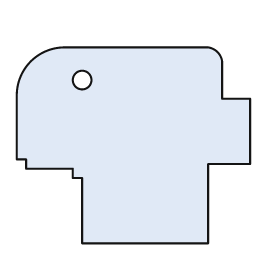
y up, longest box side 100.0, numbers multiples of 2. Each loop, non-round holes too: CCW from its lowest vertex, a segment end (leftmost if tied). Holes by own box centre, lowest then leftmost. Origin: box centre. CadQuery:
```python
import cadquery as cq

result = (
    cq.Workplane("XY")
    .moveTo(-22.0, -42.0)
    .lineTo(32.0, -42.0)
    .lineTo(32.0, -8.0)
    .lineTo(50.0, -8.0)
    .lineTo(50.0, 20.0)
    .lineTo(38.0, 20.0)
    .lineTo(38.0, 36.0)
    .threePointArc((36.0, 40.0), (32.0, 42.0))
    .lineTo(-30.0, 42.0)
    .threePointArc((-44.0, 36.0), (-50.0, 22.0))
    .lineTo(-50.0, -6.0)
    .lineTo(-46.0, -6.0)
    .lineTo(-46.0, -10.0)
    .lineTo(-26.0, -10.0)
    .lineTo(-26.0, -14.0)
    .lineTo(-22.0, -14.0)
    .close()
    .moveTo(-22.0, 28.0)
    .circle(4.0)
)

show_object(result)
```